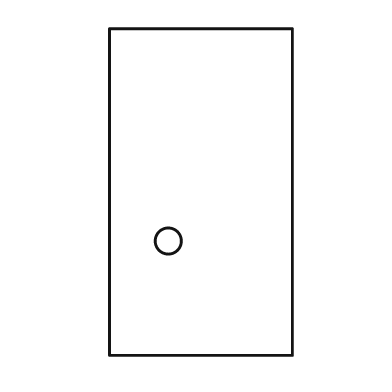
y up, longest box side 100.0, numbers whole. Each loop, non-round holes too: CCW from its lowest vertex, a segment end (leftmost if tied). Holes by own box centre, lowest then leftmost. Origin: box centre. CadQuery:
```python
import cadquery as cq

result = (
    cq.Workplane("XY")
    .moveTo(-28.0, -50.0)
    .lineTo(28.0, -50.0)
    .lineTo(28.0, 50.0)
    .lineTo(-28.0, 50.0)
    .close()
    .moveTo(-10.0, -15.0)
    .circle(4.0)
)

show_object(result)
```